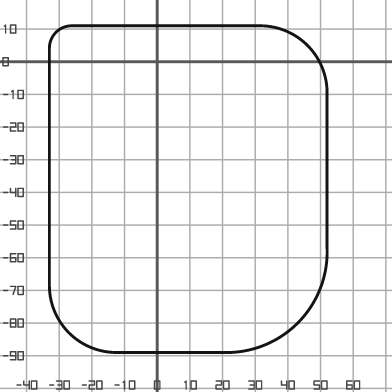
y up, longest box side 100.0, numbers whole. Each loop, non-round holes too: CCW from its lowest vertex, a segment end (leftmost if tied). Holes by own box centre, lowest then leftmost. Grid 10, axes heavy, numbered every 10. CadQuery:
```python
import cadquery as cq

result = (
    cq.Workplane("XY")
    .moveTo(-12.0, -89.0)
    .lineTo(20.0, -89.0)
    .threePointArc((43.0, -80.0), (52.0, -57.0))
    .lineTo(52.0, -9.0)
    .threePointArc((46.0, 5.0), (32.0, 11.0))
    .lineTo(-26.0, 11.0)
    .threePointArc((-31.0, 9.0), (-33.0, 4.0))
    .lineTo(-33.0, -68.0)
    .threePointArc((-27.0, -83.0), (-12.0, -89.0))
    .close()
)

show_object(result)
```